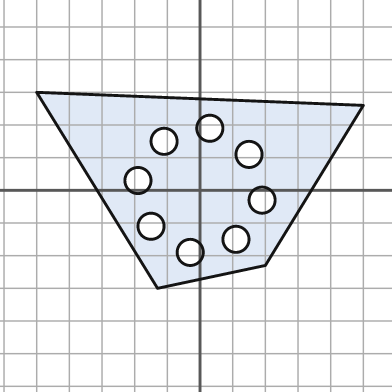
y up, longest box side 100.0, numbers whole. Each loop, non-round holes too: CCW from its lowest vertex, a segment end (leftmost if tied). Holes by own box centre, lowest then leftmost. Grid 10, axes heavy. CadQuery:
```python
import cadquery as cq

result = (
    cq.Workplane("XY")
    .moveTo(-13.0, -30.0)
    .lineTo(20.0, -23.0)
    .lineTo(50.0, 26.0)
    .lineTo(-50.0, 30.0)
    .close()
    .moveTo(-3.0, -19.0)
    .circle(4.0)
    .moveTo(11.0, -15.0)
    .circle(4.0)
    .moveTo(-15.0, -11.0)
    .circle(4.0)
    .moveTo(19.0, -3.0)
    .circle(4.0)
    .moveTo(-19.0, 3.0)
    .circle(4.0)
    .moveTo(15.0, 11.0)
    .circle(4.0)
    .moveTo(-11.0, 15.0)
    .circle(4.0)
    .moveTo(3.0, 19.0)
    .circle(4.0)
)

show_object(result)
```